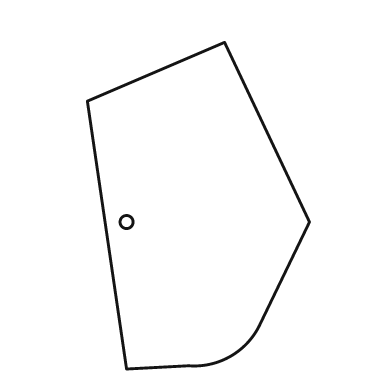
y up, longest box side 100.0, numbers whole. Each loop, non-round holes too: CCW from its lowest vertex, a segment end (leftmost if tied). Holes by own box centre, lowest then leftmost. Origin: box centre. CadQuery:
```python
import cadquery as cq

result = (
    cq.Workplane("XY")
    .moveTo(-22.0, -50.0)
    .lineTo(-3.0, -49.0)
    .threePointArc((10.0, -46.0), (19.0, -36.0))
    .lineTo(34.0, -5.0)
    .lineTo(8.0, 50.0)
    .lineTo(-34.0, 32.0)
    .close()
    .moveTo(-22.0, -5.0)
    .circle(2.0)
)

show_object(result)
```